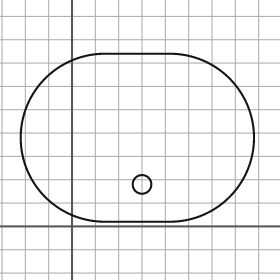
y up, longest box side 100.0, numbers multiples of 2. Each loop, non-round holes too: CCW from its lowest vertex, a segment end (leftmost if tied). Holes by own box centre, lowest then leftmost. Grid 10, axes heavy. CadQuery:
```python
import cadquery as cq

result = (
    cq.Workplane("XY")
    .moveTo(14.0, 2.0)
    .lineTo(42.0, 2.0)
    .threePointArc((78.0, 38.0), (42.0, 74.0))
    .lineTo(14.0, 74.0)
    .threePointArc((-22.0, 38.0), (14.0, 2.0))
    .close()
    .moveTo(30.0, 18.0)
    .circle(4.0)
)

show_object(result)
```